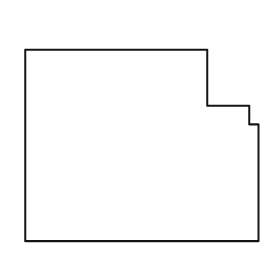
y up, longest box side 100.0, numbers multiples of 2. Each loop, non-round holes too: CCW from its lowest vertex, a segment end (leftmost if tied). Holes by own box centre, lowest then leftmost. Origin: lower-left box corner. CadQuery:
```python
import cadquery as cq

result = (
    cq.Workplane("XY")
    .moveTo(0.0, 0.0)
    .lineTo(100.0, 0.0)
    .lineTo(100.0, 50.0)
    .lineTo(96.0, 50.0)
    .lineTo(96.0, 58.0)
    .lineTo(78.0, 58.0)
    .lineTo(78.0, 82.0)
    .lineTo(0.0, 82.0)
    .close()
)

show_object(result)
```